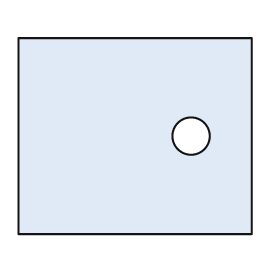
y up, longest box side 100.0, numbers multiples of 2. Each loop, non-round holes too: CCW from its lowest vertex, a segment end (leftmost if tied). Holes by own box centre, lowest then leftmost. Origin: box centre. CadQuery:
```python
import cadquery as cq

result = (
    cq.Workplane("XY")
    .moveTo(-50.0, -42.0)
    .lineTo(50.0, -42.0)
    .lineTo(50.0, 42.0)
    .lineTo(-50.0, 42.0)
    .close()
    .moveTo(24.0, 0.0)
    .circle(8.0)
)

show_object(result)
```